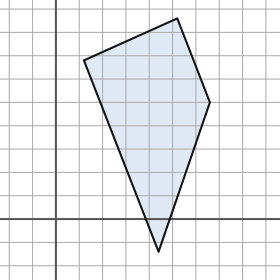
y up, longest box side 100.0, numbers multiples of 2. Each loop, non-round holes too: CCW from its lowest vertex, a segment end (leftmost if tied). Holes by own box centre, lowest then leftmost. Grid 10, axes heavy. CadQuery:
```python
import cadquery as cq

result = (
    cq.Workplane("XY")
    .moveTo(44.0, -14.0)
    .lineTo(66.0, 50.0)
    .lineTo(52.0, 86.0)
    .lineTo(12.0, 68.0)
    .close()
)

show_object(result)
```